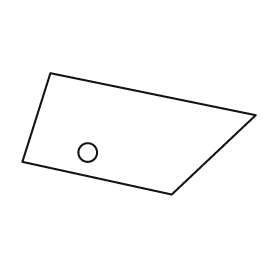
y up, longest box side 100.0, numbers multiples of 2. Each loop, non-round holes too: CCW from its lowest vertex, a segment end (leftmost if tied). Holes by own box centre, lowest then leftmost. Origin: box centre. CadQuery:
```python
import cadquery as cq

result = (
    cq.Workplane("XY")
    .moveTo(14.0, -26.0)
    .lineTo(50.0, 8.0)
    .lineTo(-38.0, 26.0)
    .lineTo(-50.0, -12.0)
    .close()
    .moveTo(-22.0, -8.0)
    .circle(4.0)
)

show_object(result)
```